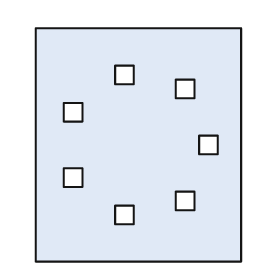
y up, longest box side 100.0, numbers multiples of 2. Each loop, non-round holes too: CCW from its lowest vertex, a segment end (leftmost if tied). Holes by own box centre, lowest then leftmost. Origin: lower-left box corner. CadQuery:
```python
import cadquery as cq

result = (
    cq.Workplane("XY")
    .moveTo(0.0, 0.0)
    .lineTo(88.0, 0.0)
    .lineTo(88.0, 100.0)
    .lineTo(0.0, 100.0)
    .close()
    .moveTo(34.0, 16.0)
    .lineTo(42.0, 16.0)
    .lineTo(42.0, 24.0)
    .lineTo(34.0, 24.0)
    .close()
    .moveTo(60.0, 22.0)
    .lineTo(68.0, 22.0)
    .lineTo(68.0, 30.0)
    .lineTo(60.0, 30.0)
    .close()
    .moveTo(12.0, 32.0)
    .lineTo(20.0, 32.0)
    .lineTo(20.0, 40.0)
    .lineTo(12.0, 40.0)
    .close()
    .moveTo(70.0, 46.0)
    .lineTo(78.0, 46.0)
    .lineTo(78.0, 54.0)
    .lineTo(70.0, 54.0)
    .close()
    .moveTo(12.0, 60.0)
    .lineTo(20.0, 60.0)
    .lineTo(20.0, 68.0)
    .lineTo(12.0, 68.0)
    .close()
    .moveTo(60.0, 70.0)
    .lineTo(68.0, 70.0)
    .lineTo(68.0, 78.0)
    .lineTo(60.0, 78.0)
    .close()
    .moveTo(34.0, 76.0)
    .lineTo(42.0, 76.0)
    .lineTo(42.0, 84.0)
    .lineTo(34.0, 84.0)
    .close()
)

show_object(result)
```